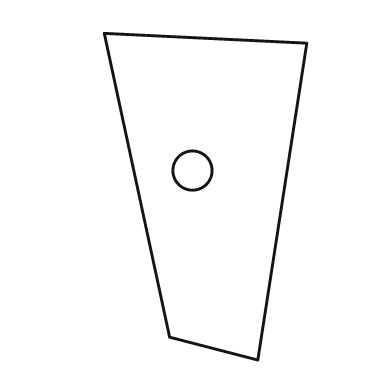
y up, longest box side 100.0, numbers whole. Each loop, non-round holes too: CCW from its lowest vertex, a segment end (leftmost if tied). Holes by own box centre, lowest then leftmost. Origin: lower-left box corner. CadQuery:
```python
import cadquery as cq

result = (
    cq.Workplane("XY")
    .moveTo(47.0, 0.0)
    .lineTo(62.0, 97.0)
    .lineTo(0.0, 100.0)
    .lineTo(20.0, 7.0)
    .close()
    .moveTo(27.0, 58.0)
    .circle(6.0)
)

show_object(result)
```